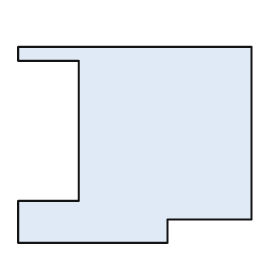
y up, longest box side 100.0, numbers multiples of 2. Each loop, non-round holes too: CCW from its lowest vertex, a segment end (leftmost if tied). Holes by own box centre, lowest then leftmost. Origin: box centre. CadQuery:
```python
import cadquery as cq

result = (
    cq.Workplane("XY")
    .moveTo(-50.0, -42.0)
    .lineTo(14.0, -42.0)
    .lineTo(14.0, -32.0)
    .lineTo(50.0, -32.0)
    .lineTo(50.0, 42.0)
    .lineTo(-50.0, 42.0)
    .lineTo(-50.0, 36.0)
    .lineTo(-24.0, 36.0)
    .lineTo(-24.0, -24.0)
    .lineTo(-50.0, -24.0)
    .close()
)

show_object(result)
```